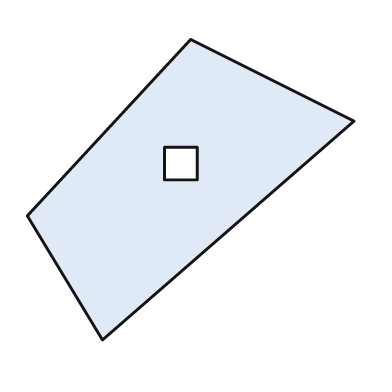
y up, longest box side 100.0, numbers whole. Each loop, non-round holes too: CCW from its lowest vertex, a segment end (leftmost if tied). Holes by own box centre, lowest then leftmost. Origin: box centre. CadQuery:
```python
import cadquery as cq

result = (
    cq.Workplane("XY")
    .moveTo(-27.0, -46.0)
    .lineTo(50.0, 21.0)
    .lineTo(0.0, 46.0)
    .lineTo(-50.0, -8.0)
    .close()
    .moveTo(-8.0, 3.0)
    .lineTo(2.0, 3.0)
    .lineTo(2.0, 13.0)
    .lineTo(-8.0, 13.0)
    .close()
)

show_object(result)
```